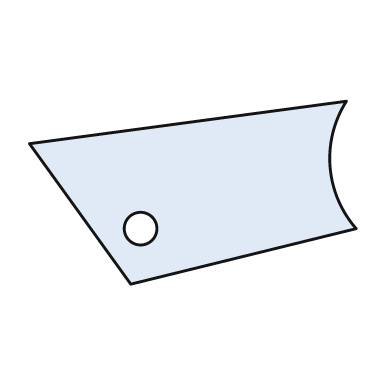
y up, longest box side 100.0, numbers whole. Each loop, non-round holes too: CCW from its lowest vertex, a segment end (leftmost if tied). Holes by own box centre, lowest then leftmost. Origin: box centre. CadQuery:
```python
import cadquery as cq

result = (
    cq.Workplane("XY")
    .moveTo(-19.0, -28.0)
    .lineTo(50.0, -11.0)
    .threePointArc((42.0, 8.0), (47.0, 28.0))
    .lineTo(-50.0, 15.0)
    .close()
    .moveTo(-16.0, -11.0)
    .circle(5.0)
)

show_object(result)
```